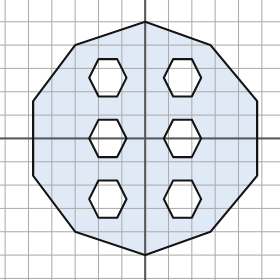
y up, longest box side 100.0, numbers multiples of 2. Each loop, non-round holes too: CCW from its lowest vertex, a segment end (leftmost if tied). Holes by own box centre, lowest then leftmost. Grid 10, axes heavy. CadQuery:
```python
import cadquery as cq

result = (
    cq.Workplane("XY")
    .moveTo(0.0, -50.0)
    .lineTo(28.0, -40.0)
    .lineTo(48.0, -16.0)
    .lineTo(48.0, 16.0)
    .lineTo(28.0, 40.0)
    .lineTo(0.0, 50.0)
    .lineTo(-30.0, 40.0)
    .lineTo(-48.0, 16.0)
    .lineTo(-48.0, -16.0)
    .lineTo(-30.0, -40.0)
    .close()
    .moveTo(-20.0, -34.0)
    .lineTo(-12.0, -34.0)
    .lineTo(-8.0, -26.0)
    .lineTo(-12.0, -18.0)
    .lineTo(-20.0, -18.0)
    .lineTo(-24.0, -26.0)
    .close()
    .moveTo(12.0, -34.0)
    .lineTo(20.0, -34.0)
    .lineTo(24.0, -26.0)
    .lineTo(20.0, -18.0)
    .lineTo(12.0, -18.0)
    .lineTo(8.0, -26.0)
    .close()
    .moveTo(-20.0, -8.0)
    .lineTo(-12.0, -8.0)
    .lineTo(-8.0, 0.0)
    .lineTo(-12.0, 8.0)
    .lineTo(-20.0, 8.0)
    .lineTo(-24.0, 0.0)
    .close()
    .moveTo(12.0, -8.0)
    .lineTo(20.0, -8.0)
    .lineTo(24.0, 0.0)
    .lineTo(20.0, 8.0)
    .lineTo(12.0, 8.0)
    .lineTo(8.0, 0.0)
    .close()
    .moveTo(-20.0, 18.0)
    .lineTo(-12.0, 18.0)
    .lineTo(-8.0, 26.0)
    .lineTo(-12.0, 34.0)
    .lineTo(-20.0, 34.0)
    .lineTo(-24.0, 26.0)
    .close()
    .moveTo(12.0, 18.0)
    .lineTo(20.0, 18.0)
    .lineTo(24.0, 26.0)
    .lineTo(20.0, 34.0)
    .lineTo(12.0, 34.0)
    .lineTo(8.0, 26.0)
    .close()
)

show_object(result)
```